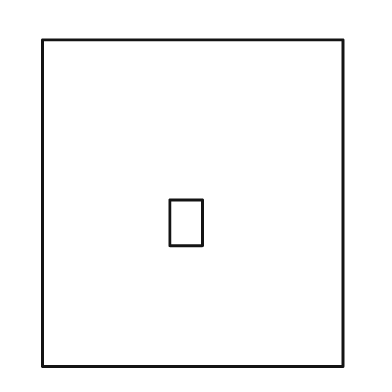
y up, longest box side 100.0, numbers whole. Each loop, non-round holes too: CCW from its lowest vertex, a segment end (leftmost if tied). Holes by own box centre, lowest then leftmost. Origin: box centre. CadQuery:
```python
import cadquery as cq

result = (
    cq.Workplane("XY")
    .moveTo(-46.0, -50.0)
    .lineTo(46.0, -50.0)
    .lineTo(46.0, 50.0)
    .lineTo(-46.0, 50.0)
    .close()
    .moveTo(-7.0, -13.0)
    .lineTo(3.0, -13.0)
    .lineTo(3.0, 1.0)
    .lineTo(-7.0, 1.0)
    .close()
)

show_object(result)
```